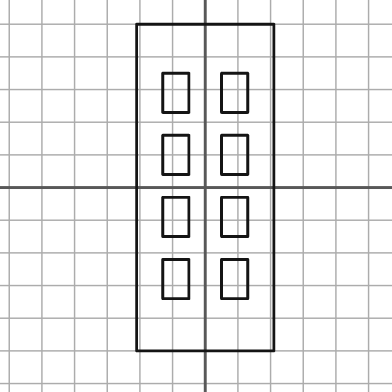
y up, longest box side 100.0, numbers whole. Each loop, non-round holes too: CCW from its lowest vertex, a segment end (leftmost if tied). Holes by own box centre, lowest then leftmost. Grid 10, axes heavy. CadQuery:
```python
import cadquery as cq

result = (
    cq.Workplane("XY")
    .moveTo(-21.0, -50.0)
    .lineTo(21.0, -50.0)
    .lineTo(21.0, 50.0)
    .lineTo(-21.0, 50.0)
    .close()
    .moveTo(-13.0, -34.0)
    .lineTo(-5.0, -34.0)
    .lineTo(-5.0, -22.0)
    .lineTo(-13.0, -22.0)
    .close()
    .moveTo(5.0, -34.0)
    .lineTo(13.0, -34.0)
    .lineTo(13.0, -22.0)
    .lineTo(5.0, -22.0)
    .close()
    .moveTo(-13.0, -15.0)
    .lineTo(-5.0, -15.0)
    .lineTo(-5.0, -3.0)
    .lineTo(-13.0, -3.0)
    .close()
    .moveTo(5.0, -15.0)
    .lineTo(13.0, -15.0)
    .lineTo(13.0, -3.0)
    .lineTo(5.0, -3.0)
    .close()
    .moveTo(-13.0, 4.0)
    .lineTo(-5.0, 4.0)
    .lineTo(-5.0, 16.0)
    .lineTo(-13.0, 16.0)
    .close()
    .moveTo(5.0, 4.0)
    .lineTo(13.0, 4.0)
    .lineTo(13.0, 16.0)
    .lineTo(5.0, 16.0)
    .close()
    .moveTo(-13.0, 23.0)
    .lineTo(-5.0, 23.0)
    .lineTo(-5.0, 35.0)
    .lineTo(-13.0, 35.0)
    .close()
    .moveTo(5.0, 23.0)
    .lineTo(13.0, 23.0)
    .lineTo(13.0, 35.0)
    .lineTo(5.0, 35.0)
    .close()
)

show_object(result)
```